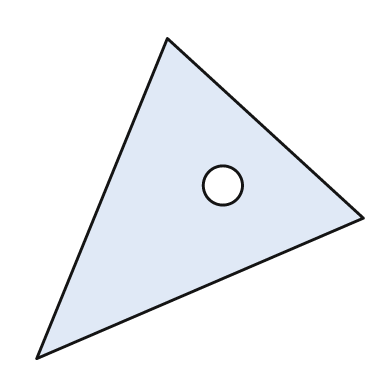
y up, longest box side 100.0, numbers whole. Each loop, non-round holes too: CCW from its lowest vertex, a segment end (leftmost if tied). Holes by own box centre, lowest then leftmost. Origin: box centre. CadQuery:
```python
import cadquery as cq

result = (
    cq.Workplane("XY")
    .moveTo(-50.0, -49.0)
    .lineTo(50.0, -6.0)
    .lineTo(-10.0, 49.0)
    .close()
    .moveTo(7.0, 4.0)
    .circle(6.0)
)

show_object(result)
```